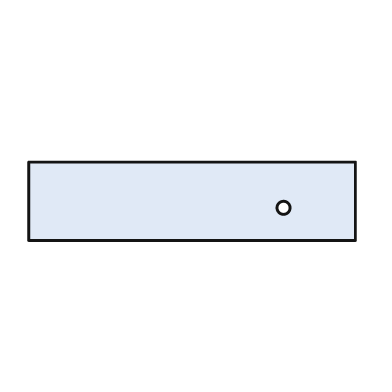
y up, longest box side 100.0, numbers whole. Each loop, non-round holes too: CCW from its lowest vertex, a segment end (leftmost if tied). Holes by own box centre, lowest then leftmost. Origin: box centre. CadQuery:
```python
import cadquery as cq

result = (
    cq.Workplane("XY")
    .moveTo(-50.0, -12.0)
    .lineTo(50.0, -12.0)
    .lineTo(50.0, 12.0)
    .lineTo(-50.0, 12.0)
    .close()
    .moveTo(28.0, -2.0)
    .circle(2.0)
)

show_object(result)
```